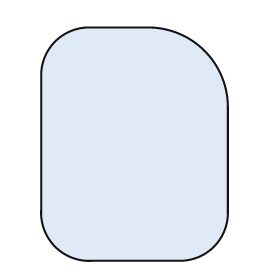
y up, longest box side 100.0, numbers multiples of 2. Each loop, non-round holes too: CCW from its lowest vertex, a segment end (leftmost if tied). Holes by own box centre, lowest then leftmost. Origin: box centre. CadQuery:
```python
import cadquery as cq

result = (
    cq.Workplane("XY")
    .moveTo(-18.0, -50.0)
    .lineTo(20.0, -50.0)
    .threePointArc((34.0, -44.0), (40.0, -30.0))
    .lineTo(40.0, 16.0)
    .threePointArc((30.0, 40.0), (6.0, 50.0))
    .lineTo(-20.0, 50.0)
    .threePointArc((-34.0, 44.0), (-40.0, 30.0))
    .lineTo(-40.0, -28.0)
    .threePointArc((-34.0, -44.0), (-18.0, -50.0))
    .close()
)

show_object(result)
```